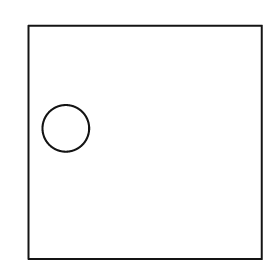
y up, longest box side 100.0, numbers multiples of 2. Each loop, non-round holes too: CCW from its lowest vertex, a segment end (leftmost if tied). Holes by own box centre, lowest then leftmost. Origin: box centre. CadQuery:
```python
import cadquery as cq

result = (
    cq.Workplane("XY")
    .moveTo(-50.0, -50.0)
    .lineTo(50.0, -50.0)
    .lineTo(50.0, 50.0)
    .lineTo(-50.0, 50.0)
    .close()
    .moveTo(-34.0, 6.0)
    .circle(10.0)
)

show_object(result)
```